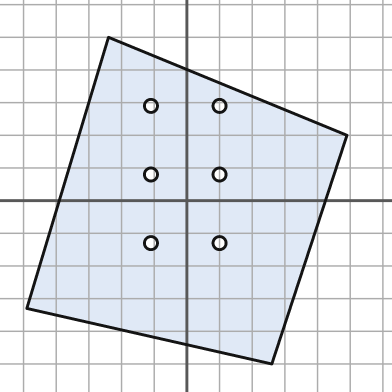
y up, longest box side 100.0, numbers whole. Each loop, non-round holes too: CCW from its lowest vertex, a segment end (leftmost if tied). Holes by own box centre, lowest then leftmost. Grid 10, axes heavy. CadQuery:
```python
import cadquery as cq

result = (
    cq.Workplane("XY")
    .moveTo(26.0, -50.0)
    .lineTo(49.0, 20.0)
    .lineTo(-24.0, 50.0)
    .lineTo(-49.0, -33.0)
    .close()
    .moveTo(-11.0, -13.0)
    .circle(2.0)
    .moveTo(10.0, -13.0)
    .circle(2.0)
    .moveTo(-11.0, 8.0)
    .circle(2.0)
    .moveTo(10.0, 8.0)
    .circle(2.0)
    .moveTo(-11.0, 29.0)
    .circle(2.0)
    .moveTo(10.0, 29.0)
    .circle(2.0)
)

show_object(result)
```